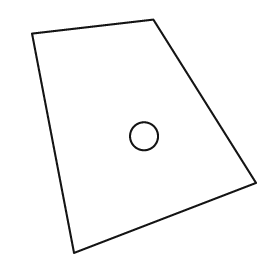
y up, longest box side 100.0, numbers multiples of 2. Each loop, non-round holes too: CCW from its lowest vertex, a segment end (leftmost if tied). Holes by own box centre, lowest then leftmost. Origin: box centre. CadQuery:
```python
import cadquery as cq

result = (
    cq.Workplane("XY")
    .moveTo(-30.0, -50.0)
    .lineTo(48.0, -20.0)
    .lineTo(4.0, 50.0)
    .lineTo(-48.0, 44.0)
    .close()
    .moveTo(0.0, 0.0)
    .circle(6.0)
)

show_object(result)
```